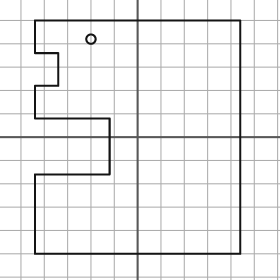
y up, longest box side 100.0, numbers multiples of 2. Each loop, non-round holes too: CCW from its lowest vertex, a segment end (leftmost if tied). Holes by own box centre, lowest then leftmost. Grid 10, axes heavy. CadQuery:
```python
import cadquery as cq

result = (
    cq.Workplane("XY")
    .moveTo(-44.0, -50.0)
    .lineTo(44.0, -50.0)
    .lineTo(44.0, 50.0)
    .lineTo(-44.0, 50.0)
    .lineTo(-44.0, 36.0)
    .lineTo(-34.0, 36.0)
    .lineTo(-34.0, 22.0)
    .lineTo(-44.0, 22.0)
    .lineTo(-44.0, 8.0)
    .lineTo(-12.0, 8.0)
    .lineTo(-12.0, -16.0)
    .lineTo(-44.0, -16.0)
    .close()
    .moveTo(-20.0, 42.0)
    .circle(2.0)
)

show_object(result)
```